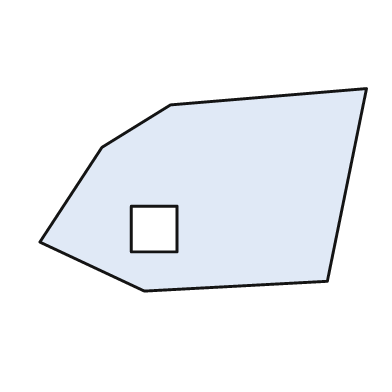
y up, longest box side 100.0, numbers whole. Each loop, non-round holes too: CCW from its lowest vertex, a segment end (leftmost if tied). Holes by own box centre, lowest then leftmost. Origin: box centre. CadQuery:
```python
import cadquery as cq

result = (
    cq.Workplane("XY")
    .moveTo(-18.0, -31.0)
    .lineTo(38.0, -28.0)
    .lineTo(50.0, 31.0)
    .lineTo(-10.0, 26.0)
    .lineTo(-31.0, 13.0)
    .lineTo(-50.0, -16.0)
    .close()
    .moveTo(-22.0, -19.0)
    .lineTo(-8.0, -19.0)
    .lineTo(-8.0, -5.0)
    .lineTo(-22.0, -5.0)
    .close()
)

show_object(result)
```